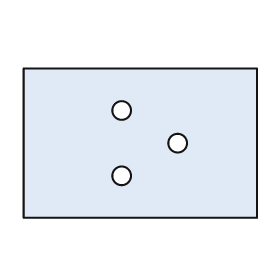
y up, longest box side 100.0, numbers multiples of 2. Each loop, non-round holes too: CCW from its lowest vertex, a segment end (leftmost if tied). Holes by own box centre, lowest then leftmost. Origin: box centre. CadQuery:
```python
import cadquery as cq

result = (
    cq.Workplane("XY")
    .moveTo(-50.0, -32.0)
    .lineTo(50.0, -32.0)
    .lineTo(50.0, 32.0)
    .lineTo(-50.0, 32.0)
    .close()
    .moveTo(-8.0, -14.0)
    .circle(4.0)
    .moveTo(16.0, 0.0)
    .circle(4.0)
    .moveTo(-8.0, 14.0)
    .circle(4.0)
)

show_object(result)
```